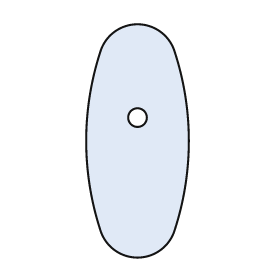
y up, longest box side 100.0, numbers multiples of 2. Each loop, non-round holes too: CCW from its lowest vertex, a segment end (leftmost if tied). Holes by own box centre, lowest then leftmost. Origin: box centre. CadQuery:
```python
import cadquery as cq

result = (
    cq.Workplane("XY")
    .moveTo(-16.0, -38.0)
    .threePointArc((0.0, -50.0), (16.0, -38.0))
    .threePointArc((22.0, 0.0), (16.0, 38.0))
    .threePointArc((0.0, 50.0), (-16.0, 38.0))
    .threePointArc((-22.0, 0.0), (-16.0, -38.0))
    .close()
    .moveTo(0.0, 10.0)
    .circle(4.0)
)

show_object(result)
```